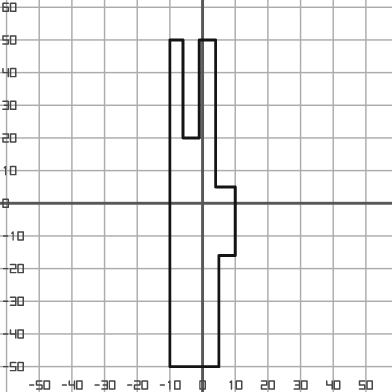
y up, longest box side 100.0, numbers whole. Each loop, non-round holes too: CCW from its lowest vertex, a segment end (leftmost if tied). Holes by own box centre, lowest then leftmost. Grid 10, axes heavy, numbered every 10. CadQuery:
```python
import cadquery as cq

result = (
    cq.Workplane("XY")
    .moveTo(-10.0, -50.0)
    .lineTo(5.0, -50.0)
    .lineTo(5.0, -16.0)
    .lineTo(10.0, -16.0)
    .lineTo(10.0, 5.0)
    .lineTo(4.0, 5.0)
    .lineTo(4.0, 50.0)
    .lineTo(-1.0, 50.0)
    .lineTo(-1.0, 20.0)
    .lineTo(-6.0, 20.0)
    .lineTo(-6.0, 50.0)
    .lineTo(-10.0, 50.0)
    .close()
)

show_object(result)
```